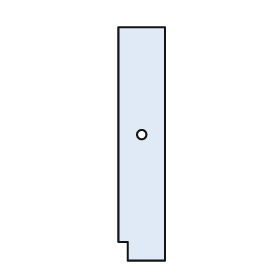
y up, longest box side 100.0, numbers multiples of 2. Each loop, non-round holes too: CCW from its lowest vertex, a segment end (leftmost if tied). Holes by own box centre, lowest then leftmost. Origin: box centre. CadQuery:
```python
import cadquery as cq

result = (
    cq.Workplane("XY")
    .moveTo(-6.0, -50.0)
    .lineTo(10.0, -50.0)
    .lineTo(10.0, 50.0)
    .lineTo(-10.0, 50.0)
    .lineTo(-10.0, -42.0)
    .lineTo(-6.0, -42.0)
    .close()
    .moveTo(0.0, 4.0)
    .circle(2.0)
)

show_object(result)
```